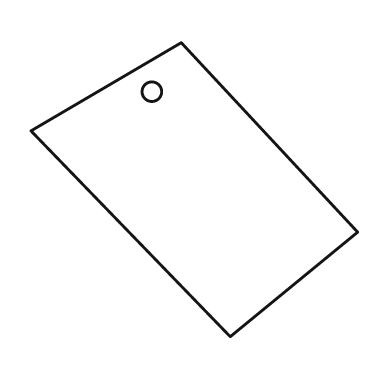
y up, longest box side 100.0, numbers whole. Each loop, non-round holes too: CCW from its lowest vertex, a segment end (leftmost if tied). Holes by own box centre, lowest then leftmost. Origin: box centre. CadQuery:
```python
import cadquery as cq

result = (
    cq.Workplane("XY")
    .moveTo(11.0, -45.0)
    .lineTo(50.0, -13.0)
    .lineTo(-4.0, 45.0)
    .lineTo(-50.0, 18.0)
    .close()
    .moveTo(-13.0, 30.0)
    .circle(3.0)
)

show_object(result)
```